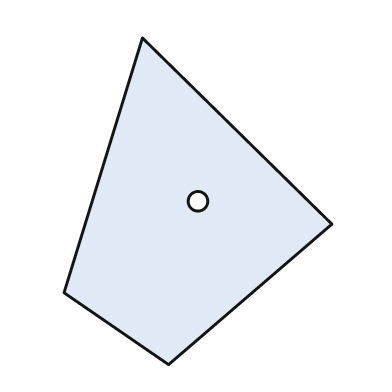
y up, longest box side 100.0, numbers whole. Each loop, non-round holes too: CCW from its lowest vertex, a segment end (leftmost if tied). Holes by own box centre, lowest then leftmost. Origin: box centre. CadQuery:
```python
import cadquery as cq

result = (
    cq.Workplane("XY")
    .moveTo(-9.0, -50.0)
    .lineTo(41.0, -7.0)
    .lineTo(-17.0, 50.0)
    .lineTo(-41.0, -28.0)
    .close()
    .moveTo(0.0, 0.0)
    .circle(3.0)
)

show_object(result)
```